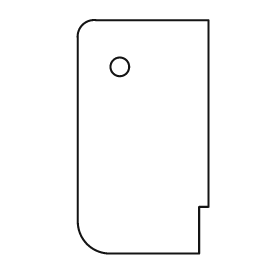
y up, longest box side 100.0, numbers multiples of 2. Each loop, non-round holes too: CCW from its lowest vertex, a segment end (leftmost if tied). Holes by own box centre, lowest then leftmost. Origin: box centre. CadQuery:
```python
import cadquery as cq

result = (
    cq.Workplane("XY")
    .moveTo(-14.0, -50.0)
    .lineTo(24.0, -50.0)
    .lineTo(24.0, -30.0)
    .lineTo(28.0, -30.0)
    .lineTo(28.0, 50.0)
    .lineTo(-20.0, 50.0)
    .threePointArc((-26.0, 48.0), (-28.0, 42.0))
    .lineTo(-28.0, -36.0)
    .threePointArc((-24.0, -46.0), (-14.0, -50.0))
    .close()
    .moveTo(-10.0, 30.0)
    .circle(4.0)
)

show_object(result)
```